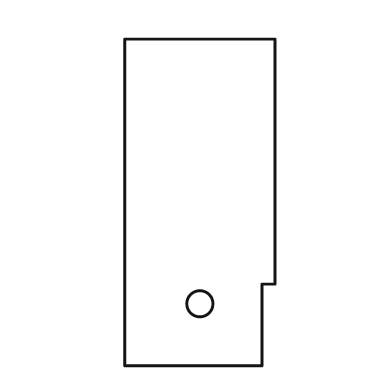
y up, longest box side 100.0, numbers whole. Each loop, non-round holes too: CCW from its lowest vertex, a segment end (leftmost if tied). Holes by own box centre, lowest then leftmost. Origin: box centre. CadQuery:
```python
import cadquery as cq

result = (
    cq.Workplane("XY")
    .moveTo(-23.0, -50.0)
    .lineTo(19.0, -50.0)
    .lineTo(19.0, -25.0)
    .lineTo(23.0, -25.0)
    .lineTo(23.0, 50.0)
    .lineTo(-23.0, 50.0)
    .close()
    .moveTo(0.0, -31.0)
    .circle(4.0)
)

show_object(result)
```